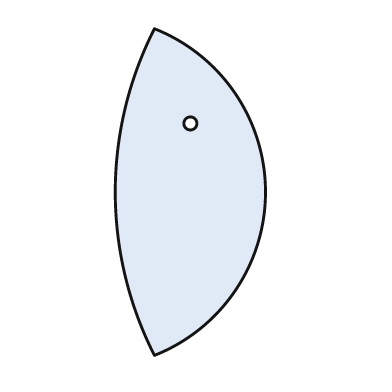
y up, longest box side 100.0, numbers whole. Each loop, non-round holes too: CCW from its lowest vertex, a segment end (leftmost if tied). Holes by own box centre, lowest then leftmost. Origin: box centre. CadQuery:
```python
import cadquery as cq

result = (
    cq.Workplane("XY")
    .moveTo(-11.0, -50.0)
    .threePointArc((23.0, 0.0), (-11.0, 50.0))
    .threePointArc((-23.0, 0.0), (-11.0, -50.0))
    .close()
    .moveTo(0.0, 21.0)
    .circle(2.0)
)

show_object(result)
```